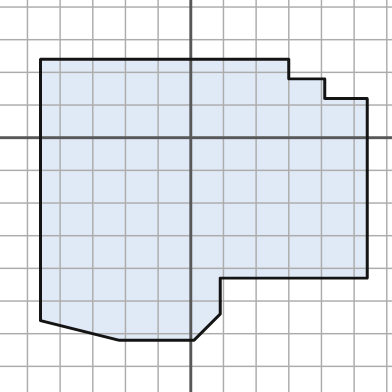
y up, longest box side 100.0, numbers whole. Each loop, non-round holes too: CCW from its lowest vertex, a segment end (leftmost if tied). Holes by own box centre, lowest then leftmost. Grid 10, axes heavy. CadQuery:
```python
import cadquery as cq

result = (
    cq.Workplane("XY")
    .moveTo(-22.0, -62.0)
    .lineTo(1.0, -62.0)
    .lineTo(9.0, -54.0)
    .lineTo(9.0, -43.0)
    .lineTo(54.0, -43.0)
    .lineTo(54.0, 12.0)
    .lineTo(41.0, 12.0)
    .lineTo(41.0, 18.0)
    .lineTo(30.0, 18.0)
    .lineTo(30.0, 24.0)
    .lineTo(-46.0, 24.0)
    .lineTo(-46.0, -56.0)
    .close()
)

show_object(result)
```